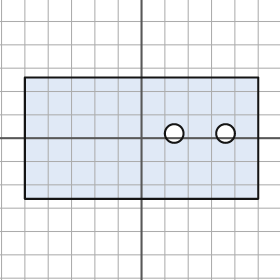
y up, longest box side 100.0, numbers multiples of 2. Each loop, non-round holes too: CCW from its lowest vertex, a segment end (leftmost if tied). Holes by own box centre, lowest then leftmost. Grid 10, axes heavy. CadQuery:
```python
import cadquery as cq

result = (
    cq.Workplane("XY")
    .moveTo(-50.0, -26.0)
    .lineTo(50.0, -26.0)
    .lineTo(50.0, 26.0)
    .lineTo(-50.0, 26.0)
    .close()
    .moveTo(14.0, 2.0)
    .circle(4.0)
    .moveTo(36.0, 2.0)
    .circle(4.0)
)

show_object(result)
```